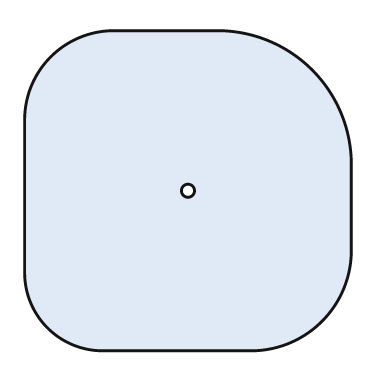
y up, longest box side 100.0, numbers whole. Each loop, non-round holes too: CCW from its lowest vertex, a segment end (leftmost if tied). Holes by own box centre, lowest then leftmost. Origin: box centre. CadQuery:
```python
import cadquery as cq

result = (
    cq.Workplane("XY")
    .moveTo(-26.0, -49.0)
    .lineTo(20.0, -49.0)
    .threePointArc((41.0, -40.0), (50.0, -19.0))
    .lineTo(50.0, 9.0)
    .threePointArc((38.0, 37.0), (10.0, 49.0))
    .lineTo(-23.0, 49.0)
    .threePointArc((-42.0, 41.0), (-50.0, 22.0))
    .lineTo(-50.0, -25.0)
    .threePointArc((-43.0, -42.0), (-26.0, -49.0))
    .close()
    .moveTo(0.0, 0.0)
    .circle(2.0)
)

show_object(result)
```